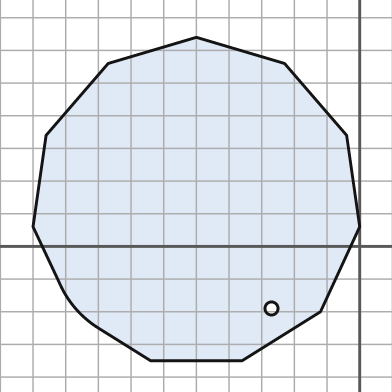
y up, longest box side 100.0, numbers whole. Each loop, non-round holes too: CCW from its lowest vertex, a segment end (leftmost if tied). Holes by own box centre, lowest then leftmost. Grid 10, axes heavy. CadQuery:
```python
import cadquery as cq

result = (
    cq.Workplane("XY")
    .moveTo(-64.0, -35.0)
    .lineTo(-36.0, -35.0)
    .lineTo(-12.0, -20.0)
    .lineTo(0.0, 6.0)
    .lineTo(-4.0, 34.0)
    .lineTo(-23.0, 56.0)
    .lineTo(-50.0, 64.0)
    .lineTo(-77.0, 56.0)
    .lineTo(-96.0, 34.0)
    .lineTo(-100.0, 6.0)
    .lineTo(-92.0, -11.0)
    .threePointArc((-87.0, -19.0), (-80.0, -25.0))
    .close()
    .moveTo(-27.0, -19.0)
    .circle(2.0)
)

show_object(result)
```